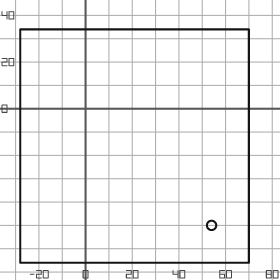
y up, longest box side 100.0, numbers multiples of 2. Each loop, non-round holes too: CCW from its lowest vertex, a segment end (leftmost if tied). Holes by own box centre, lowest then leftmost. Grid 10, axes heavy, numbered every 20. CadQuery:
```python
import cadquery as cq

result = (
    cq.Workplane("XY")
    .moveTo(-28.0, -66.0)
    .lineTo(70.0, -66.0)
    .lineTo(70.0, 34.0)
    .lineTo(-28.0, 34.0)
    .close()
    .moveTo(54.0, -50.0)
    .circle(2.0)
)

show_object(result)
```